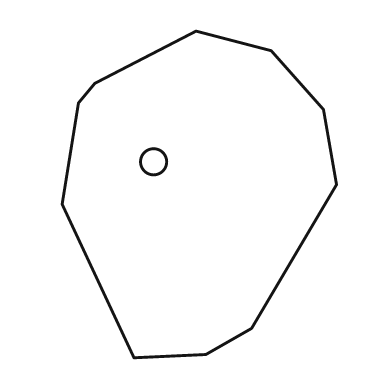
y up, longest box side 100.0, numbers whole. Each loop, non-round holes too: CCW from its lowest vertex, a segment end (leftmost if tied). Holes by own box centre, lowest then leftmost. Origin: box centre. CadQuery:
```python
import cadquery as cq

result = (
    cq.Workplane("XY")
    .moveTo(-20.0, -50.0)
    .lineTo(2.0, -49.0)
    .lineTo(16.0, -41.0)
    .lineTo(42.0, 3.0)
    .lineTo(38.0, 26.0)
    .lineTo(22.0, 44.0)
    .lineTo(-1.0, 50.0)
    .lineTo(-32.0, 34.0)
    .lineTo(-37.0, 28.0)
    .lineTo(-42.0, -3.0)
    .close()
    .moveTo(-14.0, 10.0)
    .circle(4.0)
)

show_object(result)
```